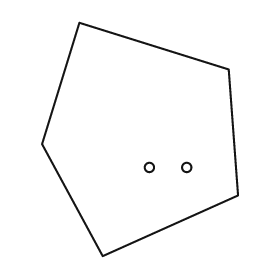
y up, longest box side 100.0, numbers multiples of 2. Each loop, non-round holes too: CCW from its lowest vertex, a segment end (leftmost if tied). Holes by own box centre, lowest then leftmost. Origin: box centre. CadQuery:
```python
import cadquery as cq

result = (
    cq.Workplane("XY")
    .moveTo(-16.0, -50.0)
    .lineTo(42.0, -24.0)
    .lineTo(38.0, 30.0)
    .lineTo(-26.0, 50.0)
    .lineTo(-42.0, -2.0)
    .close()
    .moveTo(4.0, -12.0)
    .circle(2.0)
    .moveTo(20.0, -12.0)
    .circle(2.0)
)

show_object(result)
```